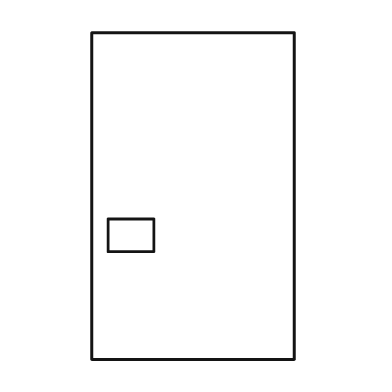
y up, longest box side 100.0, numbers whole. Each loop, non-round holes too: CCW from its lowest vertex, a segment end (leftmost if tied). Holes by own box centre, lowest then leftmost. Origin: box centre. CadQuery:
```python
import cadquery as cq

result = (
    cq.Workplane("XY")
    .moveTo(-31.0, -50.0)
    .lineTo(31.0, -50.0)
    .lineTo(31.0, 50.0)
    .lineTo(-31.0, 50.0)
    .close()
    .moveTo(-26.0, -17.0)
    .lineTo(-12.0, -17.0)
    .lineTo(-12.0, -7.0)
    .lineTo(-26.0, -7.0)
    .close()
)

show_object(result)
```